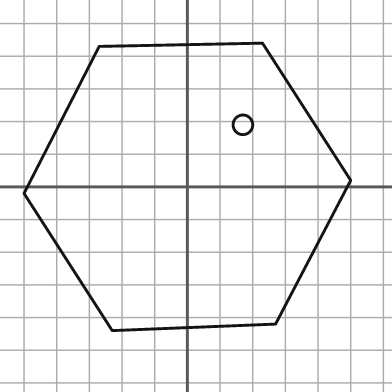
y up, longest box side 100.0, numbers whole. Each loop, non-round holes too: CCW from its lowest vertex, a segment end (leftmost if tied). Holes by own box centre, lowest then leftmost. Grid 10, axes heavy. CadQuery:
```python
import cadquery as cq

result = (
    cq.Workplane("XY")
    .moveTo(-23.0, -44.0)
    .lineTo(27.0, -42.0)
    .lineTo(50.0, 2.0)
    .lineTo(23.0, 44.0)
    .lineTo(-27.0, 43.0)
    .lineTo(-50.0, -2.0)
    .close()
    .moveTo(17.0, 19.0)
    .circle(3.0)
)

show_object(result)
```